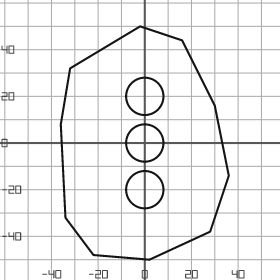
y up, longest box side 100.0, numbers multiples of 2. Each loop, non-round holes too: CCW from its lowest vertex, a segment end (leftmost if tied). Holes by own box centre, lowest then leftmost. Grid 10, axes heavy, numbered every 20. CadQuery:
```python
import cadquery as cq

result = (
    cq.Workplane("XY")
    .moveTo(2.0, -50.0)
    .lineTo(28.0, -38.0)
    .lineTo(36.0, -14.0)
    .lineTo(30.0, 16.0)
    .lineTo(16.0, 44.0)
    .lineTo(-2.0, 50.0)
    .lineTo(-32.0, 32.0)
    .lineTo(-36.0, 8.0)
    .lineTo(-34.0, -32.0)
    .lineTo(-22.0, -48.0)
    .close()
    .moveTo(0.0, -20.0)
    .circle(8.0)
    .moveTo(0.0, 0.0)
    .circle(8.0)
    .moveTo(0.0, 20.0)
    .circle(8.0)
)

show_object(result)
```